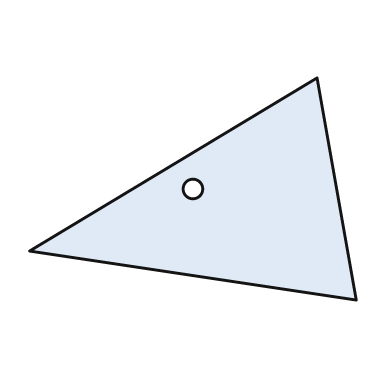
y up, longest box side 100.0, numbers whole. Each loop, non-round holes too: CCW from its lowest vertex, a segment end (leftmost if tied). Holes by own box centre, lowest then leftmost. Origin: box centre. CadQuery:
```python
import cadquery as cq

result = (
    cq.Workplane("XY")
    .moveTo(50.0, -34.0)
    .lineTo(38.0, 34.0)
    .lineTo(-50.0, -19.0)
    .close()
    .moveTo(0.0, 0.0)
    .circle(3.0)
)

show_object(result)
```